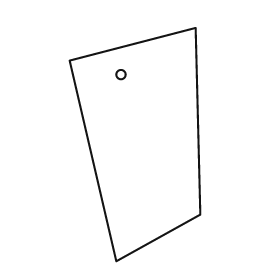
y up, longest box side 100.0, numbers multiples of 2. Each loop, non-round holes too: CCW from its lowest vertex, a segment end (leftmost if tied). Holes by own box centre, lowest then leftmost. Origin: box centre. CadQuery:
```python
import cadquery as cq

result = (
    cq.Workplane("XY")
    .moveTo(-8.0, -50.0)
    .lineTo(28.0, -30.0)
    .lineTo(26.0, 50.0)
    .lineTo(-28.0, 36.0)
    .close()
    .moveTo(-6.0, 30.0)
    .circle(2.0)
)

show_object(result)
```